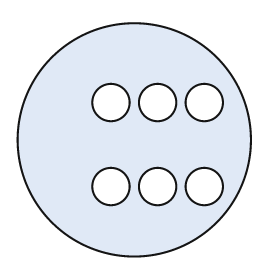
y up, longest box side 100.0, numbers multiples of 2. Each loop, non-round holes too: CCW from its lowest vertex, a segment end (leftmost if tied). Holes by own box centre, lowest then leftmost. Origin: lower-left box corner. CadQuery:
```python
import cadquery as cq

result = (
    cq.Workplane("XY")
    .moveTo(50.0, 50.0)
    .circle(50.0)
    .moveTo(40.0, 30.0)
    .circle(8.0)
    .moveTo(60.0, 30.0)
    .circle(8.0)
    .moveTo(80.0, 30.0)
    .circle(8.0)
    .moveTo(40.0, 66.0)
    .circle(8.0)
    .moveTo(60.0, 66.0)
    .circle(8.0)
    .moveTo(80.0, 66.0)
    .circle(8.0)
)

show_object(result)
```